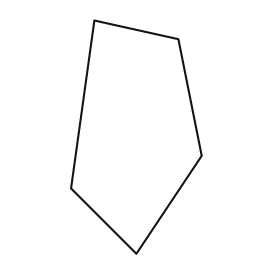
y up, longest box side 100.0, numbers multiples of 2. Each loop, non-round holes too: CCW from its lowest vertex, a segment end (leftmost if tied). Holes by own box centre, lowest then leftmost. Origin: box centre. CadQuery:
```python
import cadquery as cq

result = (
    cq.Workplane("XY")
    .moveTo(0.0, -50.0)
    .lineTo(28.0, -8.0)
    .lineTo(18.0, 42.0)
    .lineTo(-18.0, 50.0)
    .lineTo(-28.0, -22.0)
    .close()
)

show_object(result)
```